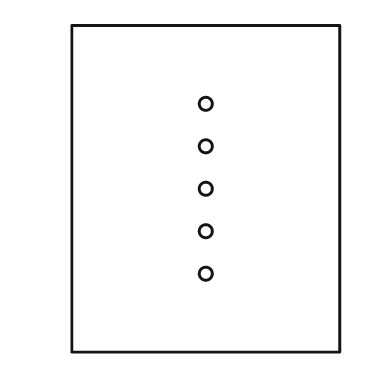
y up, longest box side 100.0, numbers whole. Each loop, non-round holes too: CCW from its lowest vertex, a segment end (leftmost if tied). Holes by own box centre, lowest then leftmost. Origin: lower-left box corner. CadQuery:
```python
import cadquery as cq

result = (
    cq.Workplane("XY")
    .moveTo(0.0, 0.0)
    .lineTo(82.0, 0.0)
    .lineTo(82.0, 100.0)
    .lineTo(0.0, 100.0)
    .close()
    .moveTo(41.0, 24.0)
    .circle(2.0)
    .moveTo(41.0, 37.0)
    .circle(2.0)
    .moveTo(41.0, 50.0)
    .circle(2.0)
    .moveTo(41.0, 63.0)
    .circle(2.0)
    .moveTo(41.0, 76.0)
    .circle(2.0)
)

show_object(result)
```